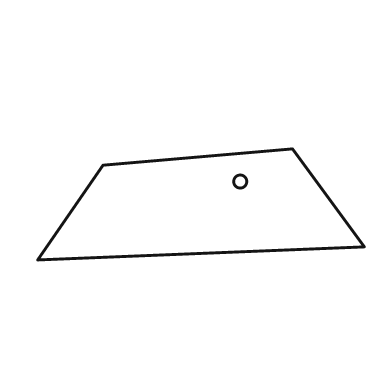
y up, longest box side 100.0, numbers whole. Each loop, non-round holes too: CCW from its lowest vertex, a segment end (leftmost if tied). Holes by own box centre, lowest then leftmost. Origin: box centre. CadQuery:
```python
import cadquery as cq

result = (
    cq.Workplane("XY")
    .moveTo(-50.0, -17.0)
    .lineTo(50.0, -13.0)
    .lineTo(28.0, 17.0)
    .lineTo(-30.0, 12.0)
    .close()
    .moveTo(12.0, 7.0)
    .circle(2.0)
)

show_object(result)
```